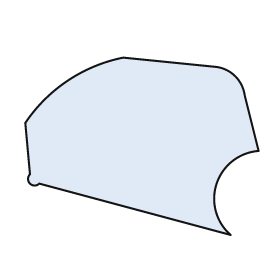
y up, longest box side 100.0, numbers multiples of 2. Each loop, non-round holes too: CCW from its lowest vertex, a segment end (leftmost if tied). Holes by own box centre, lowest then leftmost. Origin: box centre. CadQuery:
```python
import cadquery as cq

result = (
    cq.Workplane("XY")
    .moveTo(38.0, -38.0)
    .threePointArc((32.0, -16.0), (50.0, -2.0))
    .lineTo(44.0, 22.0)
    .threePointArc((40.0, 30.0), (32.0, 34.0))
    .lineTo(-8.0, 38.0)
    .threePointArc((-32.0, 28.0), (-50.0, 10.0))
    .lineTo(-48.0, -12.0)
    .threePointArc((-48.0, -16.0), (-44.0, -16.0))
    .close()
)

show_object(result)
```